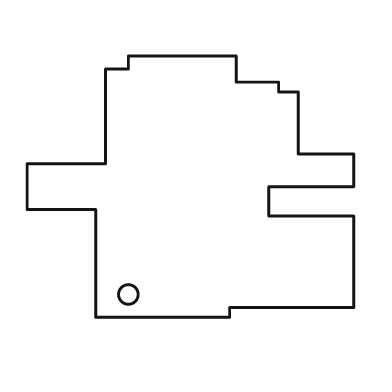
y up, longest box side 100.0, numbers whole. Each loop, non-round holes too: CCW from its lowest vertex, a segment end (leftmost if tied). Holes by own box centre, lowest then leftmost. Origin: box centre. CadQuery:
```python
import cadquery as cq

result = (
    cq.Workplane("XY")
    .moveTo(-29.0, -40.0)
    .lineTo(12.0, -40.0)
    .lineTo(12.0, -37.0)
    .lineTo(50.0, -37.0)
    .lineTo(50.0, -9.0)
    .lineTo(24.0, -9.0)
    .lineTo(24.0, 0.0)
    .lineTo(50.0, 0.0)
    .lineTo(50.0, 10.0)
    .lineTo(33.0, 10.0)
    .lineTo(33.0, 29.0)
    .lineTo(27.0, 29.0)
    .lineTo(27.0, 32.0)
    .lineTo(14.0, 32.0)
    .lineTo(14.0, 40.0)
    .lineTo(-19.0, 40.0)
    .lineTo(-19.0, 36.0)
    .lineTo(-26.0, 36.0)
    .lineTo(-26.0, 7.0)
    .lineTo(-50.0, 7.0)
    .lineTo(-50.0, -7.0)
    .lineTo(-29.0, -7.0)
    .close()
    .moveTo(-19.0, -33.0)
    .circle(3.0)
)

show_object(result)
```